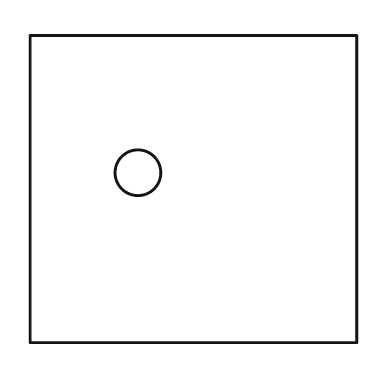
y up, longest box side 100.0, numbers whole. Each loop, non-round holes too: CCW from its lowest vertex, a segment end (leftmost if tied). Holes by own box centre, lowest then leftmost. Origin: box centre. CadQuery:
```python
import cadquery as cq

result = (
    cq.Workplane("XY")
    .moveTo(-50.0, -47.0)
    .lineTo(50.0, -47.0)
    .lineTo(50.0, 47.0)
    .lineTo(-50.0, 47.0)
    .close()
    .moveTo(-17.0, 5.0)
    .circle(7.0)
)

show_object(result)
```